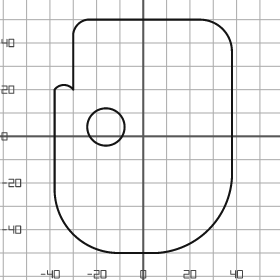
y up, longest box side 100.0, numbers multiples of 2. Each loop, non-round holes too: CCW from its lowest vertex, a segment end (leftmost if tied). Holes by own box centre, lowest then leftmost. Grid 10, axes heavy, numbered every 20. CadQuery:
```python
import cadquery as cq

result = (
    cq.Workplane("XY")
    .moveTo(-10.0, -50.0)
    .lineTo(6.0, -50.0)
    .threePointArc((28.0, -40.0), (38.0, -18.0))
    .lineTo(38.0, 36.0)
    .threePointArc((34.0, 46.0), (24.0, 50.0))
    .lineTo(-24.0, 50.0)
    .threePointArc((-28.0, 48.0), (-30.0, 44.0))
    .lineTo(-30.0, 20.0)
    .threePointArc((-34.0, 22.0), (-38.0, 20.0))
    .lineTo(-38.0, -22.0)
    .threePointArc((-30.0, -42.0), (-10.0, -50.0))
    .close()
    .moveTo(-16.0, 4.0)
    .circle(8.0)
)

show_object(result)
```